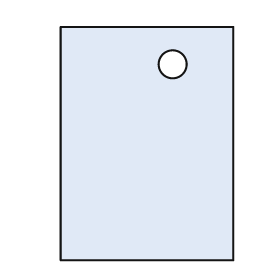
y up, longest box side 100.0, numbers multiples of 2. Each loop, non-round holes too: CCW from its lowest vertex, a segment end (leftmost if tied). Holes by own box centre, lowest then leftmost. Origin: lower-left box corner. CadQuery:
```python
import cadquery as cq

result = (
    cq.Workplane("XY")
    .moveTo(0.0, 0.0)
    .lineTo(74.0, 0.0)
    .lineTo(74.0, 100.0)
    .lineTo(0.0, 100.0)
    .close()
    .moveTo(48.0, 84.0)
    .circle(6.0)
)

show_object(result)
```